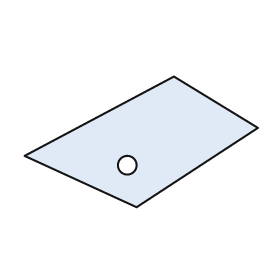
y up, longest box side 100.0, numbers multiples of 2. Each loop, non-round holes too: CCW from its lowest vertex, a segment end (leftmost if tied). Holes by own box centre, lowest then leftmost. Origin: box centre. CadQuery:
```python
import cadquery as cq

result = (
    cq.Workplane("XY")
    .moveTo(-2.0, -28.0)
    .lineTo(50.0, 6.0)
    .lineTo(14.0, 28.0)
    .lineTo(-50.0, -6.0)
    .close()
    .moveTo(-6.0, -10.0)
    .circle(4.0)
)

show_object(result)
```